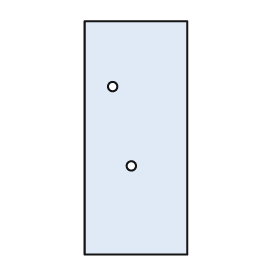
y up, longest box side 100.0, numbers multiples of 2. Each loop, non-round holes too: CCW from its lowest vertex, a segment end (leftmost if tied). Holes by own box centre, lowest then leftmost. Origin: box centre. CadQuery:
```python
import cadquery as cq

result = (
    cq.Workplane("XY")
    .moveTo(-22.0, -50.0)
    .lineTo(22.0, -50.0)
    .lineTo(22.0, 50.0)
    .lineTo(-22.0, 50.0)
    .close()
    .moveTo(-2.0, -12.0)
    .circle(2.0)
    .moveTo(-10.0, 22.0)
    .circle(2.0)
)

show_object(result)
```